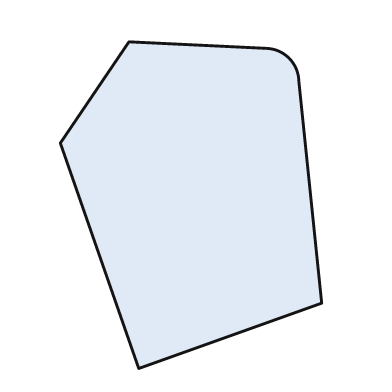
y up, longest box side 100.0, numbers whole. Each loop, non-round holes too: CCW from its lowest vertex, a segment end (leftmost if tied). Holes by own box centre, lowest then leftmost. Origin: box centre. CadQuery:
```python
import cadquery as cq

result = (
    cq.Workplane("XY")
    .moveTo(-16.0, -50.0)
    .lineTo(40.0, -30.0)
    .lineTo(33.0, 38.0)
    .threePointArc((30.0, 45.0), (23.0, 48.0))
    .lineTo(-19.0, 50.0)
    .lineTo(-40.0, 19.0)
    .close()
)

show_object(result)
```